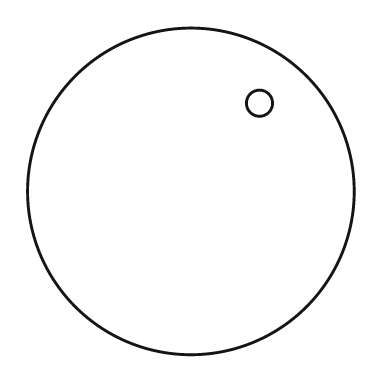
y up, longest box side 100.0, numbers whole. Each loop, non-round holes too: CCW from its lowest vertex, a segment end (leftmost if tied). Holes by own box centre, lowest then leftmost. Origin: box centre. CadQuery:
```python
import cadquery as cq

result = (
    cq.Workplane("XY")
    .moveTo(0.0, 0.0)
    .circle(50.0)
    .moveTo(21.0, 27.0)
    .circle(4.0)
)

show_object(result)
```